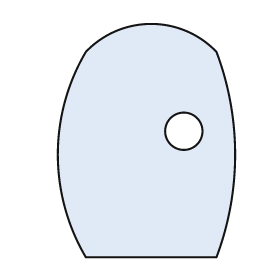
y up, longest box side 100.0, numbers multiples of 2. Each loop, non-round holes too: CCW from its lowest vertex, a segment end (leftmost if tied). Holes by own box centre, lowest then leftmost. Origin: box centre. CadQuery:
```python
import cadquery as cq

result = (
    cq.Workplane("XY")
    .moveTo(-26.0, -50.0)
    .lineTo(30.0, -50.0)
    .threePointArc((38.0, -6.0), (30.0, 38.0))
    .threePointArc((2.0, 50.0), (-26.0, 38.0))
    .threePointArc((-38.0, -6.0), (-26.0, -50.0))
    .close()
    .moveTo(16.0, 4.0)
    .circle(8.0)
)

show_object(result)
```